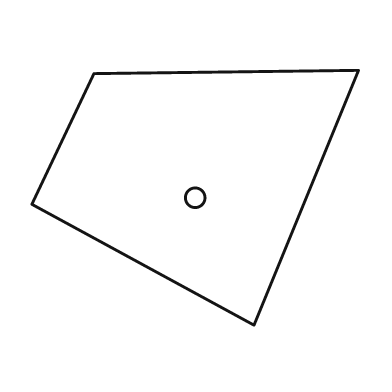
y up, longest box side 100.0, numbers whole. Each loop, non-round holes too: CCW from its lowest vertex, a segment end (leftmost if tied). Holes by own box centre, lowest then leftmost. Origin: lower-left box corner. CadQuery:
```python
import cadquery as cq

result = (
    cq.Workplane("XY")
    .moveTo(68.0, 0.0)
    .lineTo(100.0, 78.0)
    .lineTo(19.0, 77.0)
    .lineTo(0.0, 37.0)
    .close()
    .moveTo(50.0, 39.0)
    .circle(3.0)
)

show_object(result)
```